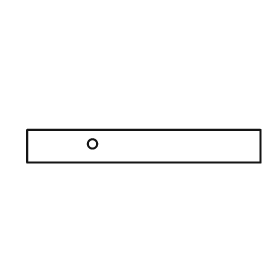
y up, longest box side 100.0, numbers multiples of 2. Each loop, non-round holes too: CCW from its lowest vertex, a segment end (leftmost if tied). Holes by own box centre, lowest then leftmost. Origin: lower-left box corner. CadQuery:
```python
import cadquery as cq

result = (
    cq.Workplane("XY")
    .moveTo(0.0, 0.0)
    .lineTo(100.0, 0.0)
    .lineTo(100.0, 14.0)
    .lineTo(0.0, 14.0)
    .close()
    .moveTo(28.0, 8.0)
    .circle(2.0)
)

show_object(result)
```